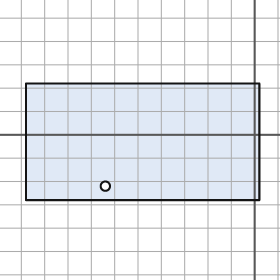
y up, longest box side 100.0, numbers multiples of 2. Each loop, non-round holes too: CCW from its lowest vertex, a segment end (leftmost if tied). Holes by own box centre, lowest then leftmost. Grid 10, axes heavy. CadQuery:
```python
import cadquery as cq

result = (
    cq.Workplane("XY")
    .moveTo(-98.0, -28.0)
    .lineTo(2.0, -28.0)
    .lineTo(2.0, 22.0)
    .lineTo(-98.0, 22.0)
    .close()
    .moveTo(-64.0, -22.0)
    .circle(2.0)
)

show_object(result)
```